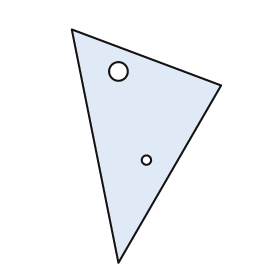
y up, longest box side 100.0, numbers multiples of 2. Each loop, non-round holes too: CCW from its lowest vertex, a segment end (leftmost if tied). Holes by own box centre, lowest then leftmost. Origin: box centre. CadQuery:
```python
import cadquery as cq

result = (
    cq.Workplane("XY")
    .moveTo(-12.0, -50.0)
    .lineTo(32.0, 26.0)
    .lineTo(-32.0, 50.0)
    .close()
    .moveTo(0.0, -6.0)
    .circle(2.0)
    .moveTo(-12.0, 32.0)
    .circle(4.0)
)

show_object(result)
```